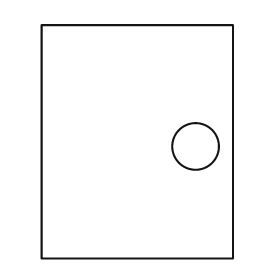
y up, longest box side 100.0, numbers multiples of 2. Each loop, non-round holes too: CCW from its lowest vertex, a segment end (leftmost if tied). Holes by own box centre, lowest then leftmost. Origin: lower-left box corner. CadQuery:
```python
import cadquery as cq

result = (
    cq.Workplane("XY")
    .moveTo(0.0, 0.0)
    .lineTo(82.0, 0.0)
    .lineTo(82.0, 100.0)
    .lineTo(0.0, 100.0)
    .close()
    .moveTo(66.0, 48.0)
    .circle(10.0)
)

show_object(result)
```